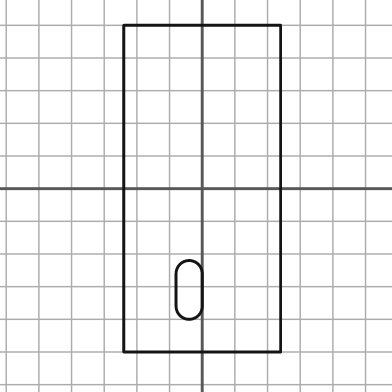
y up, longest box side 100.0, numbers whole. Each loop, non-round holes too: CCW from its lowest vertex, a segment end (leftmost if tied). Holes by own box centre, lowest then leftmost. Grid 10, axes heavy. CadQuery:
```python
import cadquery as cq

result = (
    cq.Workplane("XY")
    .moveTo(-24.0, -50.0)
    .lineTo(24.0, -50.0)
    .lineTo(24.0, 50.0)
    .lineTo(-24.0, 50.0)
    .close()
    .moveTo(-8.0, -36.0)
    .threePointArc((-4.0, -40.0), (0.0, -36.0))
    .lineTo(0.0, -26.0)
    .threePointArc((-4.0, -22.0), (-8.0, -26.0))
    .close()
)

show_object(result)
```